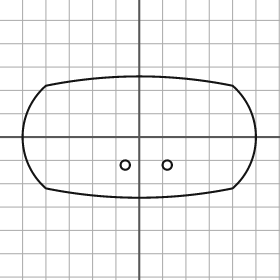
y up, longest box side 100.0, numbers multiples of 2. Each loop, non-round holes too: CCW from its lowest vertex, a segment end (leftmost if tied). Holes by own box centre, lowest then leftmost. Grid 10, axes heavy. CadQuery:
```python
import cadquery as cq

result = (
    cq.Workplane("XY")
    .moveTo(-40.0, -22.0)
    .threePointArc((0.0, -26.0), (40.0, -22.0))
    .threePointArc((50.0, 0.0), (40.0, 22.0))
    .threePointArc((0.0, 26.0), (-40.0, 22.0))
    .threePointArc((-50.0, 0.0), (-40.0, -22.0))
    .close()
    .moveTo(-6.0, -12.0)
    .circle(2.0)
    .moveTo(12.0, -12.0)
    .circle(2.0)
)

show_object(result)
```